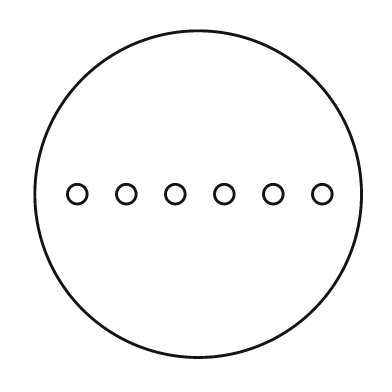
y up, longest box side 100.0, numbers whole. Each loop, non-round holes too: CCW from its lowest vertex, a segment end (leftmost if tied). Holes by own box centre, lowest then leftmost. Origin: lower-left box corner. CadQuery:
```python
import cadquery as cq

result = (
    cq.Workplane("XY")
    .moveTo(50.0, 50.0)
    .circle(50.0)
    .moveTo(13.0, 50.0)
    .circle(3.0)
    .moveTo(28.0, 50.0)
    .circle(3.0)
    .moveTo(43.0, 50.0)
    .circle(3.0)
    .moveTo(58.0, 50.0)
    .circle(3.0)
    .moveTo(73.0, 50.0)
    .circle(3.0)
    .moveTo(88.0, 50.0)
    .circle(3.0)
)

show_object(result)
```